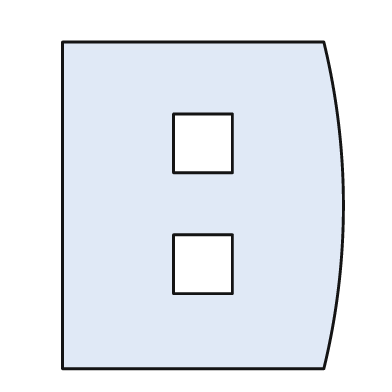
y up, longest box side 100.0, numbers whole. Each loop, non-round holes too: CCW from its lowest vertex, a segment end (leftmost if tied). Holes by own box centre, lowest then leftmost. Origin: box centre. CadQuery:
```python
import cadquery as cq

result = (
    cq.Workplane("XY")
    .moveTo(-43.0, -50.0)
    .lineTo(37.0, -50.0)
    .threePointArc((43.0, 0.0), (37.0, 50.0))
    .lineTo(-43.0, 50.0)
    .close()
    .moveTo(-9.0, -27.0)
    .lineTo(9.0, -27.0)
    .lineTo(9.0, -9.0)
    .lineTo(-9.0, -9.0)
    .close()
    .moveTo(-9.0, 10.0)
    .lineTo(9.0, 10.0)
    .lineTo(9.0, 28.0)
    .lineTo(-9.0, 28.0)
    .close()
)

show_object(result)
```